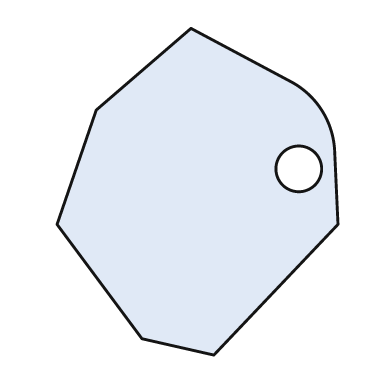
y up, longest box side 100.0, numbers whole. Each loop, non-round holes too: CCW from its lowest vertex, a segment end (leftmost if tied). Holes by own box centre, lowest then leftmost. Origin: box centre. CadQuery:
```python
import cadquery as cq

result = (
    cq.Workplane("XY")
    .moveTo(5.0, -50.0)
    .lineTo(43.0, -10.0)
    .lineTo(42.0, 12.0)
    .threePointArc((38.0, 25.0), (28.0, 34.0))
    .lineTo(-2.0, 50.0)
    .lineTo(-31.0, 25.0)
    .lineTo(-43.0, -10.0)
    .lineTo(-17.0, -45.0)
    .close()
    .moveTo(31.0, 7.0)
    .circle(7.0)
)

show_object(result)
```